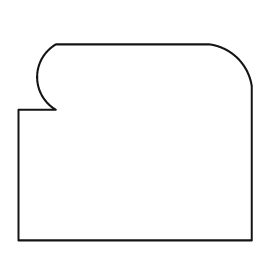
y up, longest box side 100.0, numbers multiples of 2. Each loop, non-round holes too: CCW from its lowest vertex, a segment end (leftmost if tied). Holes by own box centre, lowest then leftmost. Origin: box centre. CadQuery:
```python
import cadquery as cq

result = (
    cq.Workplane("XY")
    .moveTo(-50.0, -42.0)
    .lineTo(50.0, -42.0)
    .lineTo(50.0, 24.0)
    .threePointArc((44.0, 36.0), (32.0, 42.0))
    .lineTo(-34.0, 42.0)
    .threePointArc((-42.0, 28.0), (-34.0, 14.0))
    .lineTo(-50.0, 14.0)
    .close()
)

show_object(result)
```